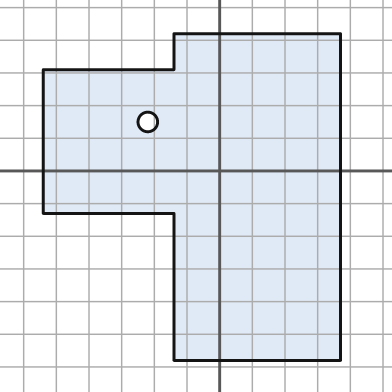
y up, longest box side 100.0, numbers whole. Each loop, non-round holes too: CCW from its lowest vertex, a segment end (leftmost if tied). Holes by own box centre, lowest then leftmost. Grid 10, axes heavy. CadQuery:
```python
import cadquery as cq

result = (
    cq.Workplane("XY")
    .moveTo(-14.0, -58.0)
    .lineTo(37.0, -58.0)
    .lineTo(37.0, 42.0)
    .lineTo(-14.0, 42.0)
    .lineTo(-14.0, 31.0)
    .lineTo(-54.0, 31.0)
    .lineTo(-54.0, -13.0)
    .lineTo(-14.0, -13.0)
    .close()
    .moveTo(-22.0, 15.0)
    .circle(3.0)
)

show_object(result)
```